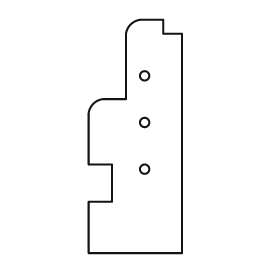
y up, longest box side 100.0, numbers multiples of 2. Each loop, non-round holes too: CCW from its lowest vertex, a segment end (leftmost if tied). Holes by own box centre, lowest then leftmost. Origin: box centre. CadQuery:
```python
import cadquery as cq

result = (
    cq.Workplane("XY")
    .moveTo(-20.0, -50.0)
    .lineTo(20.0, -50.0)
    .lineTo(20.0, 44.0)
    .lineTo(12.0, 44.0)
    .lineTo(12.0, 50.0)
    .lineTo(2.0, 50.0)
    .threePointArc((-2.0, 48.0), (-4.0, 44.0))
    .lineTo(-4.0, 16.0)
    .lineTo(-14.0, 16.0)
    .threePointArc((-18.0, 14.0), (-20.0, 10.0))
    .lineTo(-20.0, -12.0)
    .lineTo(-10.0, -12.0)
    .lineTo(-10.0, -28.0)
    .lineTo(-20.0, -28.0)
    .close()
    .moveTo(4.0, -14.0)
    .circle(2.0)
    .moveTo(4.0, 6.0)
    .circle(2.0)
    .moveTo(4.0, 26.0)
    .circle(2.0)
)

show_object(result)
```